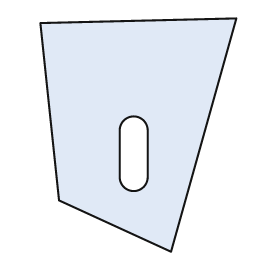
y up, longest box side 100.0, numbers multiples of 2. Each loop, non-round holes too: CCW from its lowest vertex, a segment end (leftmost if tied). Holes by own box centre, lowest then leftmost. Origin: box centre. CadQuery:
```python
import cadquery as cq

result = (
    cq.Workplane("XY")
    .moveTo(14.0, -50.0)
    .lineTo(42.0, 50.0)
    .lineTo(-42.0, 48.0)
    .lineTo(-34.0, -28.0)
    .close()
    .moveTo(-8.0, -18.0)
    .threePointArc((-2.0, -24.0), (4.0, -18.0))
    .lineTo(4.0, 2.0)
    .threePointArc((-2.0, 8.0), (-8.0, 2.0))
    .close()
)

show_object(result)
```